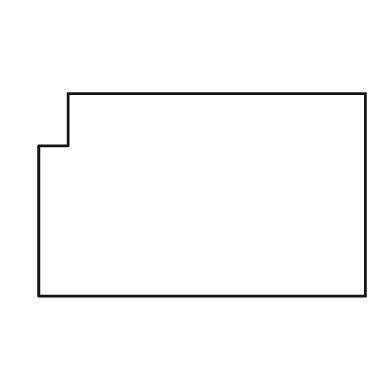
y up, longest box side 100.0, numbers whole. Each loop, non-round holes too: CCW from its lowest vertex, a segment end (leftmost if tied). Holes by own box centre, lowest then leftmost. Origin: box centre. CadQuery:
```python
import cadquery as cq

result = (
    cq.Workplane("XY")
    .moveTo(-50.0, -31.0)
    .lineTo(50.0, -31.0)
    .lineTo(50.0, 31.0)
    .lineTo(-41.0, 31.0)
    .lineTo(-41.0, 15.0)
    .lineTo(-50.0, 15.0)
    .close()
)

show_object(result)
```